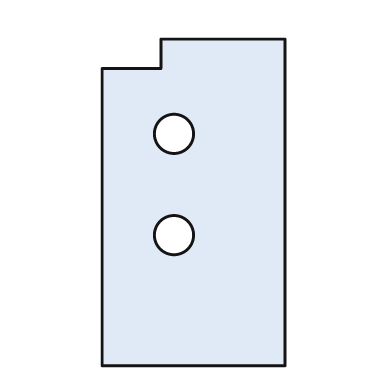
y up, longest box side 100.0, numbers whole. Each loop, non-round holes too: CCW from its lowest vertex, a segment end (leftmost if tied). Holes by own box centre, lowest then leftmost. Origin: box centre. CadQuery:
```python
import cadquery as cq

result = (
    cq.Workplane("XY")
    .moveTo(-28.0, -50.0)
    .lineTo(28.0, -50.0)
    .lineTo(28.0, 50.0)
    .lineTo(-10.0, 50.0)
    .lineTo(-10.0, 41.0)
    .lineTo(-28.0, 41.0)
    .close()
    .moveTo(-6.0, -10.0)
    .circle(6.0)
    .moveTo(-6.0, 21.0)
    .circle(6.0)
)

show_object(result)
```